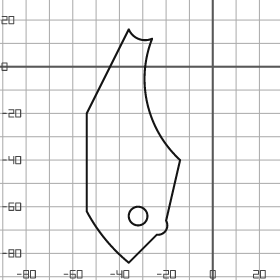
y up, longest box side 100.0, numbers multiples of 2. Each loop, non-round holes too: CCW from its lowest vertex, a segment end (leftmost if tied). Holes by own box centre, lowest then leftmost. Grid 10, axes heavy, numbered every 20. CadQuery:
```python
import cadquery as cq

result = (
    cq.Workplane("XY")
    .moveTo(-36.0, -84.0)
    .lineTo(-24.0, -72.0)
    .threePointArc((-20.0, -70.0), (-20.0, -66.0))
    .lineTo(-14.0, -40.0)
    .threePointArc((-28.0, -16.0), (-26.0, 12.0))
    .threePointArc((-32.0, 12.0), (-36.0, 16.0))
    .lineTo(-54.0, -20.0)
    .lineTo(-54.0, -62.0)
    .threePointArc((-46.0, -74.0), (-36.0, -84.0))
    .close()
    .moveTo(-32.0, -64.0)
    .circle(4.0)
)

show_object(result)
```